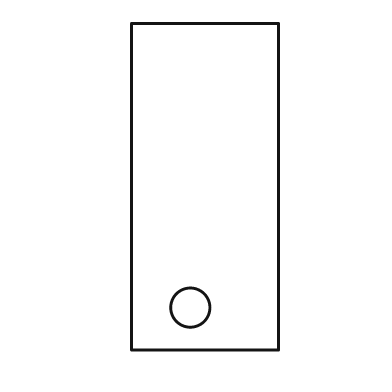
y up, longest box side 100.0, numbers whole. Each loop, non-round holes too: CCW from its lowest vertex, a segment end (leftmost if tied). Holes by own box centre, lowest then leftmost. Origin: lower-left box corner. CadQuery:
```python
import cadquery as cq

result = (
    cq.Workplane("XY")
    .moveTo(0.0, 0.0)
    .lineTo(45.0, 0.0)
    .lineTo(45.0, 100.0)
    .lineTo(0.0, 100.0)
    .close()
    .moveTo(18.0, 13.0)
    .circle(6.0)
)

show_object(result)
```